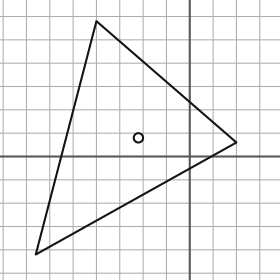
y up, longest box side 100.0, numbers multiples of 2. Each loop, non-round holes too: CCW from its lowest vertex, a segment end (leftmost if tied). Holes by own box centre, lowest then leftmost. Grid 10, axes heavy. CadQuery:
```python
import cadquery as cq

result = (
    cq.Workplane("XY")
    .moveTo(-66.0, -42.0)
    .lineTo(20.0, 6.0)
    .lineTo(-40.0, 58.0)
    .close()
    .moveTo(-22.0, 8.0)
    .circle(2.0)
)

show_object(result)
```